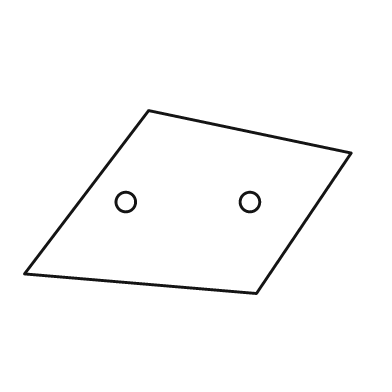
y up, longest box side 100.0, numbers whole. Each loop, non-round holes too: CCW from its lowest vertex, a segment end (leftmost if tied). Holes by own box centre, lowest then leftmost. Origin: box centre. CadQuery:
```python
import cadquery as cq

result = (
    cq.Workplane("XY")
    .moveTo(21.0, -28.0)
    .lineTo(50.0, 15.0)
    .lineTo(-12.0, 28.0)
    .lineTo(-50.0, -22.0)
    .close()
    .moveTo(-19.0, 0.0)
    .circle(3.0)
    .moveTo(19.0, 0.0)
    .circle(3.0)
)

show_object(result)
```